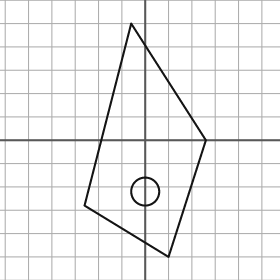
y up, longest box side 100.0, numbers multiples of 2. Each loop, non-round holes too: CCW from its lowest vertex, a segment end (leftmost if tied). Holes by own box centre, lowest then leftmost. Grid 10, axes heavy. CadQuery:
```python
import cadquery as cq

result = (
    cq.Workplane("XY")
    .moveTo(10.0, -50.0)
    .lineTo(26.0, 0.0)
    .lineTo(-6.0, 50.0)
    .lineTo(-26.0, -28.0)
    .close()
    .moveTo(0.0, -22.0)
    .circle(6.0)
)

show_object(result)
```